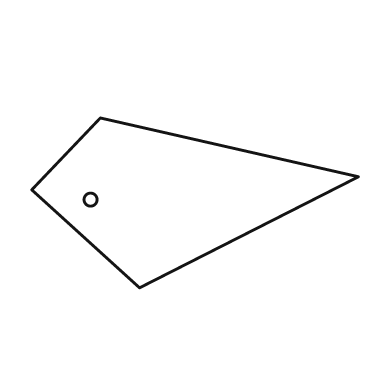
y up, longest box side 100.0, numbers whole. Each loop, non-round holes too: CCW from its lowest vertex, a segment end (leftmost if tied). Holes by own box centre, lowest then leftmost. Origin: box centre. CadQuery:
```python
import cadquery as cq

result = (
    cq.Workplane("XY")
    .moveTo(-17.0, -26.0)
    .lineTo(50.0, 8.0)
    .lineTo(-29.0, 26.0)
    .lineTo(-50.0, 4.0)
    .close()
    .moveTo(-32.0, 1.0)
    .circle(2.0)
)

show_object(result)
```